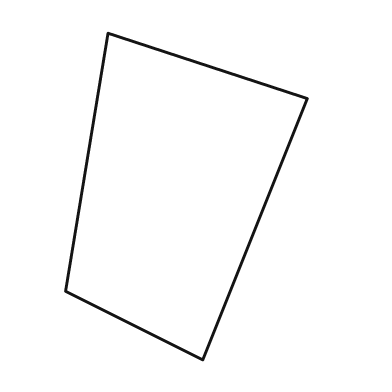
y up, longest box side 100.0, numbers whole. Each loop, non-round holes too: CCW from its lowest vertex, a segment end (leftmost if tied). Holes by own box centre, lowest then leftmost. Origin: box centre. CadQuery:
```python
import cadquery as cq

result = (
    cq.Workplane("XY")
    .moveTo(5.0, -50.0)
    .lineTo(37.0, 30.0)
    .lineTo(-24.0, 50.0)
    .lineTo(-37.0, -29.0)
    .close()
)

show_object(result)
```